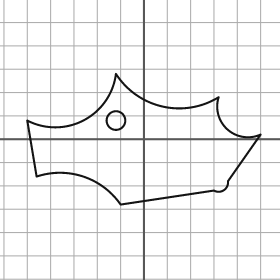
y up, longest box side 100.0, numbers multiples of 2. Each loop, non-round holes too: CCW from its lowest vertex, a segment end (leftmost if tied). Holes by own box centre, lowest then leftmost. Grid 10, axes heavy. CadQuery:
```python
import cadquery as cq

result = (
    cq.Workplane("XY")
    .moveTo(-10.0, -28.0)
    .lineTo(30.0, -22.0)
    .threePointArc((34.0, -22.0), (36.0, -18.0))
    .lineTo(50.0, 2.0)
    .threePointArc((36.0, 4.0), (32.0, 18.0))
    .threePointArc((8.0, 14.0), (-12.0, 28.0))
    .threePointArc((-26.0, 8.0), (-50.0, 8.0))
    .lineTo(-46.0, -16.0)
    .threePointArc((-26.0, -16.0), (-10.0, -28.0))
    .close()
    .moveTo(-12.0, 8.0)
    .circle(4.0)
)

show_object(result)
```